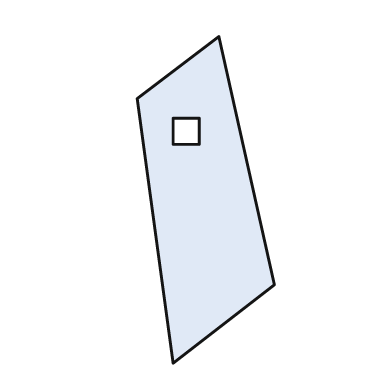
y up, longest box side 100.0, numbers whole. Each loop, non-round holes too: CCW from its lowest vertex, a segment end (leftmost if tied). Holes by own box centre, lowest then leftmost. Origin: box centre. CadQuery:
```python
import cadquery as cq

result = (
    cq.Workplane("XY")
    .moveTo(-10.0, -50.0)
    .lineTo(21.0, -26.0)
    .lineTo(4.0, 50.0)
    .lineTo(-21.0, 31.0)
    .close()
    .moveTo(-10.0, 17.0)
    .lineTo(-2.0, 17.0)
    .lineTo(-2.0, 25.0)
    .lineTo(-10.0, 25.0)
    .close()
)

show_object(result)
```